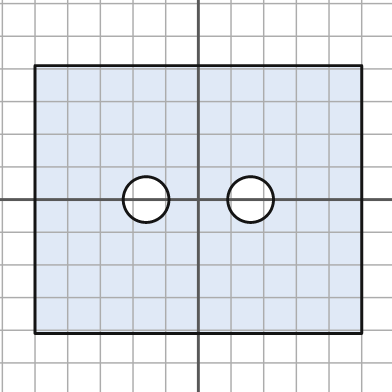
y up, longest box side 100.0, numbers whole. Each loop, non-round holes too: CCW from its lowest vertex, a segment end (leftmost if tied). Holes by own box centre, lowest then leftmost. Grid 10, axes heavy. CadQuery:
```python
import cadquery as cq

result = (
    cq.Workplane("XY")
    .moveTo(-50.0, -41.0)
    .lineTo(50.0, -41.0)
    .lineTo(50.0, 41.0)
    .lineTo(-50.0, 41.0)
    .close()
    .moveTo(-16.0, 0.0)
    .circle(7.0)
    .moveTo(16.0, 0.0)
    .circle(7.0)
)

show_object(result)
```